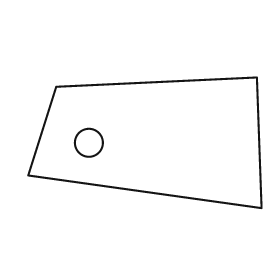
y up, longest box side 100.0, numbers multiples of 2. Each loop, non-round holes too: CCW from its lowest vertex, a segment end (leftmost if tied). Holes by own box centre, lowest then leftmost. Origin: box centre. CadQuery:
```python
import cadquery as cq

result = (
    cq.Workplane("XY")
    .moveTo(50.0, -28.0)
    .lineTo(48.0, 28.0)
    .lineTo(-38.0, 24.0)
    .lineTo(-50.0, -14.0)
    .close()
    .moveTo(-24.0, 0.0)
    .circle(6.0)
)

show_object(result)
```